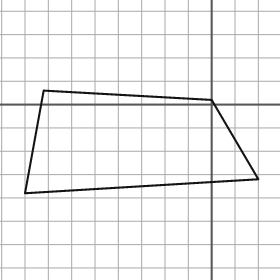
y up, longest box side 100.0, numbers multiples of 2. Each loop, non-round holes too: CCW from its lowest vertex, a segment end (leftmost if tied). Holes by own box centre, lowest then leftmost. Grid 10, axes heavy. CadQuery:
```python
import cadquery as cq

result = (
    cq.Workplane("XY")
    .moveTo(-80.0, -38.0)
    .lineTo(20.0, -32.0)
    .lineTo(0.0, 2.0)
    .lineTo(-72.0, 6.0)
    .close()
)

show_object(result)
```